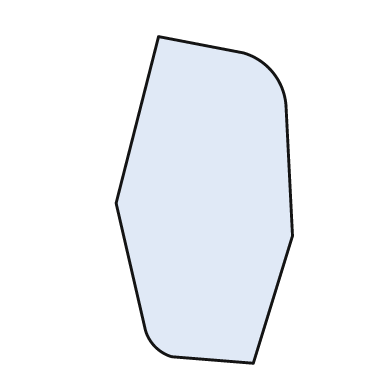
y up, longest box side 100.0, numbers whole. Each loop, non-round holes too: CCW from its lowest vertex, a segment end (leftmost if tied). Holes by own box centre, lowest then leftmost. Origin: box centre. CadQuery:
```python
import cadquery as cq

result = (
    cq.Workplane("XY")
    .moveTo(15.0, -50.0)
    .lineTo(27.0, -11.0)
    .lineTo(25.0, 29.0)
    .threePointArc((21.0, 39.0), (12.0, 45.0))
    .lineTo(-14.0, 50.0)
    .lineTo(-27.0, -1.0)
    .lineTo(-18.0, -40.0)
    .threePointArc((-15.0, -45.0), (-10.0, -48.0))
    .close()
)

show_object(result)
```